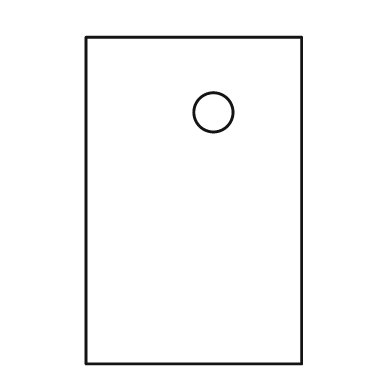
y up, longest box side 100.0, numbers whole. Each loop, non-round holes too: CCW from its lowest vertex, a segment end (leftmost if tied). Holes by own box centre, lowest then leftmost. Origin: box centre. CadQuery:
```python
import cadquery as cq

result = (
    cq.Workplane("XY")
    .moveTo(-33.0, -50.0)
    .lineTo(33.0, -50.0)
    .lineTo(33.0, 50.0)
    .lineTo(-33.0, 50.0)
    .close()
    .moveTo(6.0, 27.0)
    .circle(6.0)
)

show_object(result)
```